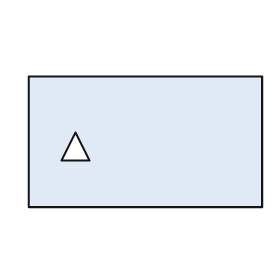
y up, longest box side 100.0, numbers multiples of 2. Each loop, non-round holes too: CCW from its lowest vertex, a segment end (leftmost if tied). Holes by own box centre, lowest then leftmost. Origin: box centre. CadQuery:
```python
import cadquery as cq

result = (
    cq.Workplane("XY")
    .moveTo(-50.0, -28.0)
    .lineTo(50.0, -28.0)
    .lineTo(50.0, 28.0)
    .lineTo(-50.0, 28.0)
    .close()
    .moveTo(-36.0, -8.0)
    .lineTo(-24.0, -8.0)
    .lineTo(-30.0, 4.0)
    .close()
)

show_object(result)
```